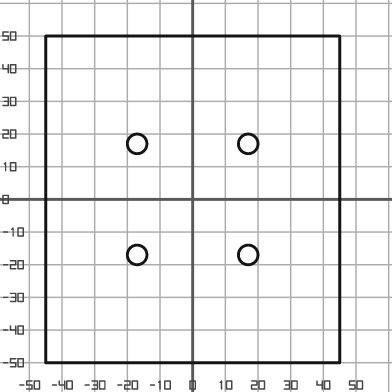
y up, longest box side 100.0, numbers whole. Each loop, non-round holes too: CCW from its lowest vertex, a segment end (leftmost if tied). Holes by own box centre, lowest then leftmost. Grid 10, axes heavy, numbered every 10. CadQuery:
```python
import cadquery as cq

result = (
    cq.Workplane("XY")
    .moveTo(-45.0, -50.0)
    .lineTo(45.0, -50.0)
    .lineTo(45.0, 50.0)
    .lineTo(-45.0, 50.0)
    .close()
    .moveTo(-17.0, -17.0)
    .circle(3.0)
    .moveTo(17.0, -17.0)
    .circle(3.0)
    .moveTo(-17.0, 17.0)
    .circle(3.0)
    .moveTo(17.0, 17.0)
    .circle(3.0)
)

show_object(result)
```